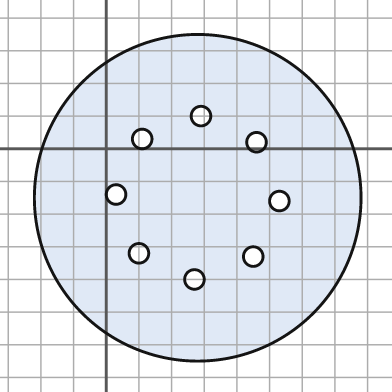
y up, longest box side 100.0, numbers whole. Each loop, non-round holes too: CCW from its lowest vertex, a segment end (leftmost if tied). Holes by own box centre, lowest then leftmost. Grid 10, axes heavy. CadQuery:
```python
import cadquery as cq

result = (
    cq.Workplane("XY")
    .moveTo(28.0, -15.0)
    .circle(50.0)
    .moveTo(27.0, -40.0)
    .circle(3.0)
    .moveTo(45.0, -33.0)
    .circle(3.0)
    .moveTo(10.0, -32.0)
    .circle(3.0)
    .moveTo(53.0, -16.0)
    .circle(3.0)
    .moveTo(3.0, -14.0)
    .circle(3.0)
    .moveTo(46.0, 2.0)
    .circle(3.0)
    .moveTo(11.0, 3.0)
    .circle(3.0)
    .moveTo(29.0, 10.0)
    .circle(3.0)
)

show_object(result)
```